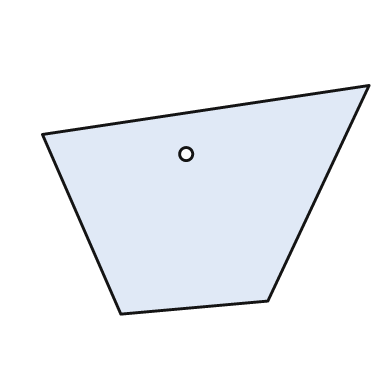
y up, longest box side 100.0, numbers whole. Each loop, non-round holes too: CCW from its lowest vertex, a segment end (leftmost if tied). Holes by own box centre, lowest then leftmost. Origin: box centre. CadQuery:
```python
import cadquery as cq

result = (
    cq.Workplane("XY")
    .moveTo(-26.0, -35.0)
    .lineTo(19.0, -31.0)
    .lineTo(50.0, 35.0)
    .lineTo(-50.0, 20.0)
    .close()
    .moveTo(-6.0, 14.0)
    .circle(2.0)
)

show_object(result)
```